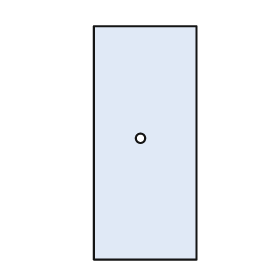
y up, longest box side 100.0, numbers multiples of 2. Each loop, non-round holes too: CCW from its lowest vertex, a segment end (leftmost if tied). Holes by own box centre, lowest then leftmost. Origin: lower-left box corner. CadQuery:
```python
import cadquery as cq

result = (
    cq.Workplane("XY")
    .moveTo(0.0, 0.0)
    .lineTo(44.0, 0.0)
    .lineTo(44.0, 100.0)
    .lineTo(0.0, 100.0)
    .close()
    .moveTo(20.0, 52.0)
    .circle(2.0)
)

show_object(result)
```